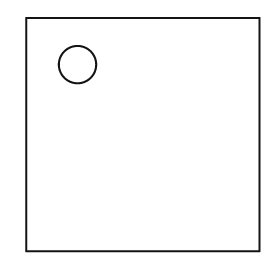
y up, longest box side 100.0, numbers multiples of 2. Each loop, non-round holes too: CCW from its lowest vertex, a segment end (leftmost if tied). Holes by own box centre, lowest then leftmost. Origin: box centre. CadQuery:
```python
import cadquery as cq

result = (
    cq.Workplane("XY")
    .moveTo(-50.0, -50.0)
    .lineTo(50.0, -50.0)
    .lineTo(50.0, 50.0)
    .lineTo(-50.0, 50.0)
    .close()
    .moveTo(-28.0, 30.0)
    .circle(8.0)
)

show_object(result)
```